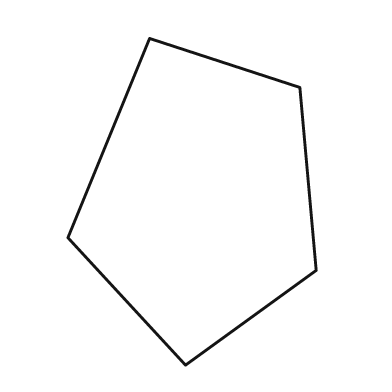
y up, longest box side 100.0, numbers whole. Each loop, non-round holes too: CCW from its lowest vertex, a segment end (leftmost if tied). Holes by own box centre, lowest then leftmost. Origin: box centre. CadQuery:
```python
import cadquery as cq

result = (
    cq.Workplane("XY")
    .moveTo(-2.0, -50.0)
    .lineTo(38.0, -21.0)
    .lineTo(33.0, 35.0)
    .lineTo(-13.0, 50.0)
    .lineTo(-38.0, -11.0)
    .close()
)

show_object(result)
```